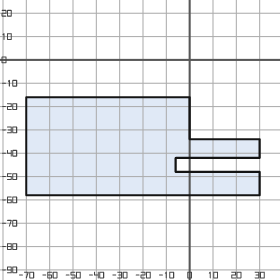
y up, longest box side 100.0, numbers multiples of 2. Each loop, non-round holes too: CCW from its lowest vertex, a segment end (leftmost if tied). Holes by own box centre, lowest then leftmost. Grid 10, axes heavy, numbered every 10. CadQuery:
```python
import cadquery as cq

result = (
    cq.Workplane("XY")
    .moveTo(-70.0, -58.0)
    .lineTo(30.0, -58.0)
    .lineTo(30.0, -48.0)
    .lineTo(-6.0, -48.0)
    .lineTo(-6.0, -42.0)
    .lineTo(30.0, -42.0)
    .lineTo(30.0, -34.0)
    .lineTo(0.0, -34.0)
    .lineTo(0.0, -16.0)
    .lineTo(-70.0, -16.0)
    .close()
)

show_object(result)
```